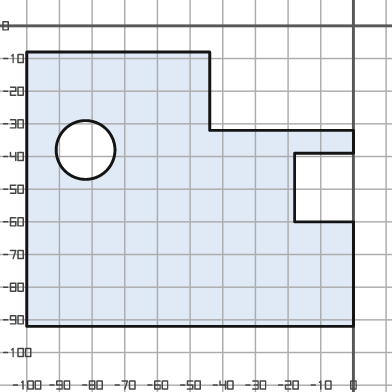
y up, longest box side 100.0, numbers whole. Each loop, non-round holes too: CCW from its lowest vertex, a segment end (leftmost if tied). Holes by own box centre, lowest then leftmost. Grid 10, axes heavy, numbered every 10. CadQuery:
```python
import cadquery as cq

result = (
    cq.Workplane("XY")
    .moveTo(-100.0, -92.0)
    .lineTo(0.0, -92.0)
    .lineTo(0.0, -60.0)
    .lineTo(-18.0, -60.0)
    .lineTo(-18.0, -39.0)
    .lineTo(0.0, -39.0)
    .lineTo(0.0, -32.0)
    .lineTo(-44.0, -32.0)
    .lineTo(-44.0, -8.0)
    .lineTo(-100.0, -8.0)
    .close()
    .moveTo(-82.0, -38.0)
    .circle(9.0)
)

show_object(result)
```